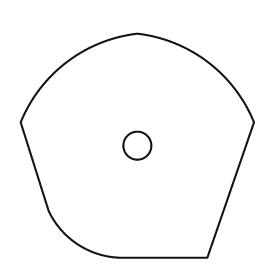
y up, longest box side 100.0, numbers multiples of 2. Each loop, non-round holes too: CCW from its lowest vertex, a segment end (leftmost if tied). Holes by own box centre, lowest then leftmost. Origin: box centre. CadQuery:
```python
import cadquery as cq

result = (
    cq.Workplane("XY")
    .moveTo(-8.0, -48.0)
    .lineTo(30.0, -48.0)
    .lineTo(50.0, 10.0)
    .threePointArc((30.0, 36.0), (0.0, 48.0))
    .threePointArc((-30.0, 36.0), (-50.0, 10.0))
    .lineTo(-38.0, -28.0)
    .threePointArc((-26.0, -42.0), (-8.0, -48.0))
    .close()
    .moveTo(0.0, 0.0)
    .circle(6.0)
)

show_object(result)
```